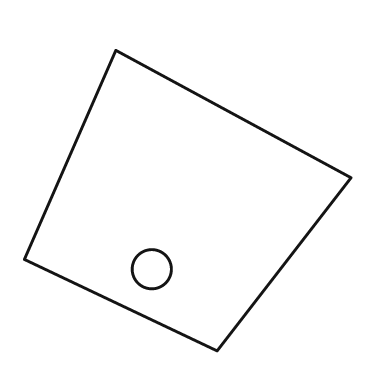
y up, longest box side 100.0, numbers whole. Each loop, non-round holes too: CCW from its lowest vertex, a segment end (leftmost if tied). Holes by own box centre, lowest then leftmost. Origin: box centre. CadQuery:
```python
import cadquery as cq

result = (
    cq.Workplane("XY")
    .moveTo(9.0, -46.0)
    .lineTo(50.0, 7.0)
    .lineTo(-22.0, 46.0)
    .lineTo(-50.0, -18.0)
    .close()
    .moveTo(-11.0, -21.0)
    .circle(6.0)
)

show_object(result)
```